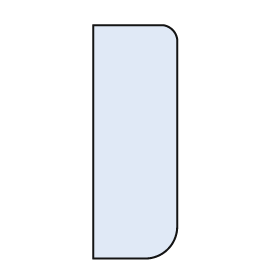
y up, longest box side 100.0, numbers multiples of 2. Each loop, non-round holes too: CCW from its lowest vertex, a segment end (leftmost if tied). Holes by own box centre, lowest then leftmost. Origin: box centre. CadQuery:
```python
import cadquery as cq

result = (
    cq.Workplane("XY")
    .moveTo(-18.0, -50.0)
    .lineTo(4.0, -50.0)
    .threePointArc((14.0, -46.0), (18.0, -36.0))
    .lineTo(18.0, 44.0)
    .threePointArc((16.0, 48.0), (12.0, 50.0))
    .lineTo(-18.0, 50.0)
    .close()
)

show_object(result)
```